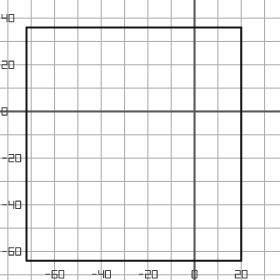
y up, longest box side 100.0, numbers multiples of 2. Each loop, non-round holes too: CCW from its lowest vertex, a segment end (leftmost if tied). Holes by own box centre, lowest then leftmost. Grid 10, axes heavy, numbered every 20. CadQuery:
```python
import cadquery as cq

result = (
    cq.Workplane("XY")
    .moveTo(-72.0, -64.0)
    .lineTo(20.0, -64.0)
    .lineTo(20.0, 36.0)
    .lineTo(-72.0, 36.0)
    .close()
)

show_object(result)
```